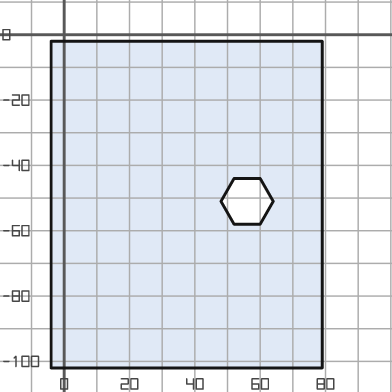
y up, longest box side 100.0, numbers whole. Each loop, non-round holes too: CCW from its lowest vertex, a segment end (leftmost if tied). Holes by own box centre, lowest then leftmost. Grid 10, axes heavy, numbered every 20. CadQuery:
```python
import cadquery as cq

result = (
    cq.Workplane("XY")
    .moveTo(-4.0, -102.0)
    .lineTo(79.0, -102.0)
    .lineTo(79.0, -2.0)
    .lineTo(-4.0, -2.0)
    .close()
    .moveTo(52.0, -58.0)
    .lineTo(60.0, -58.0)
    .lineTo(64.0, -51.0)
    .lineTo(60.0, -44.0)
    .lineTo(52.0, -44.0)
    .lineTo(48.0, -51.0)
    .close()
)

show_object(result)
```